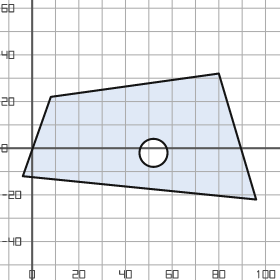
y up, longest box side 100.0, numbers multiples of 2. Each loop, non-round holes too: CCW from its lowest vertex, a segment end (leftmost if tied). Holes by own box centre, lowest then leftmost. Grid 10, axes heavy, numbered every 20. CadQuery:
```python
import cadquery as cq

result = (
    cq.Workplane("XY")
    .moveTo(96.0, -22.0)
    .lineTo(80.0, 32.0)
    .lineTo(8.0, 22.0)
    .lineTo(-4.0, -12.0)
    .close()
    .moveTo(52.0, -2.0)
    .circle(6.0)
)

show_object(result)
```